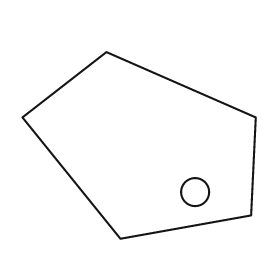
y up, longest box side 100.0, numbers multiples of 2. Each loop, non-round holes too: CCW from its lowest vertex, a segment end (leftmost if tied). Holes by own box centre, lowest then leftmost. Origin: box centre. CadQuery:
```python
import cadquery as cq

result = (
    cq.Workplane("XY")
    .moveTo(-8.0, -40.0)
    .lineTo(48.0, -30.0)
    .lineTo(50.0, 12.0)
    .lineTo(-14.0, 40.0)
    .lineTo(-50.0, 12.0)
    .close()
    .moveTo(24.0, -20.0)
    .circle(6.0)
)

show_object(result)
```